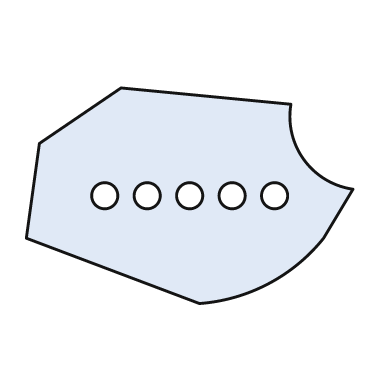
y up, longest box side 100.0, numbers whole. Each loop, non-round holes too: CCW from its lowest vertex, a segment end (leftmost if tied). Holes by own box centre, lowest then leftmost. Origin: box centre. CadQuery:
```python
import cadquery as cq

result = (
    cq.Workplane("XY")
    .moveTo(3.0, -33.0)
    .threePointArc((24.0, -27.0), (41.0, -13.0))
    .lineTo(50.0, 2.0)
    .threePointArc((35.0, 11.0), (31.0, 28.0))
    .lineTo(-21.0, 33.0)
    .lineTo(-46.0, 16.0)
    .lineTo(-50.0, -13.0)
    .close()
    .moveTo(-26.0, 0.0)
    .circle(4.0)
    .moveTo(-13.0, 0.0)
    .circle(4.0)
    .moveTo(0.0, 0.0)
    .circle(4.0)
    .moveTo(13.0, 0.0)
    .circle(4.0)
    .moveTo(26.0, 0.0)
    .circle(4.0)
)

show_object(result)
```